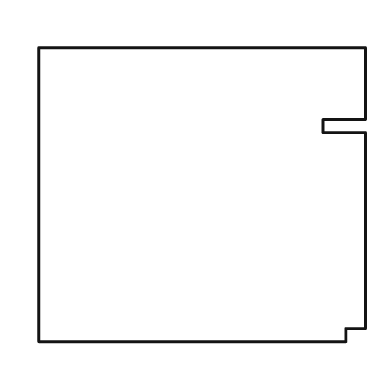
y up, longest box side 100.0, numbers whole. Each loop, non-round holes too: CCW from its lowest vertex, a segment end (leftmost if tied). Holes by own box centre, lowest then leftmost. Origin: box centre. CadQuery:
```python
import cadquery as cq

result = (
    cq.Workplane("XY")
    .moveTo(-50.0, -45.0)
    .lineTo(44.0, -45.0)
    .lineTo(44.0, -41.0)
    .lineTo(50.0, -41.0)
    .lineTo(50.0, 19.0)
    .lineTo(37.0, 19.0)
    .lineTo(37.0, 23.0)
    .lineTo(50.0, 23.0)
    .lineTo(50.0, 45.0)
    .lineTo(-50.0, 45.0)
    .close()
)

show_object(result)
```